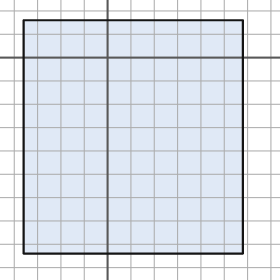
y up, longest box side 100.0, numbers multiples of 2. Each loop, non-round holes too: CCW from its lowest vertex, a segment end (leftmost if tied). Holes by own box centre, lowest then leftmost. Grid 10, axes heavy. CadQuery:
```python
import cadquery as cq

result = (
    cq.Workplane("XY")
    .moveTo(-36.0, -84.0)
    .lineTo(58.0, -84.0)
    .lineTo(58.0, 16.0)
    .lineTo(-36.0, 16.0)
    .close()
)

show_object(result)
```